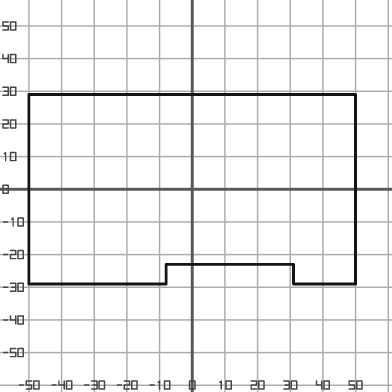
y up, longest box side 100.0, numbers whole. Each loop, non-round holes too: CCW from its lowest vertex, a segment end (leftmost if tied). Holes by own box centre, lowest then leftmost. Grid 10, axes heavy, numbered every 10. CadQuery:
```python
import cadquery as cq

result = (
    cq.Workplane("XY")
    .moveTo(-50.0, -29.0)
    .lineTo(-8.0, -29.0)
    .lineTo(-8.0, -23.0)
    .lineTo(31.0, -23.0)
    .lineTo(31.0, -29.0)
    .lineTo(50.0, -29.0)
    .lineTo(50.0, 29.0)
    .lineTo(-50.0, 29.0)
    .close()
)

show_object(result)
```